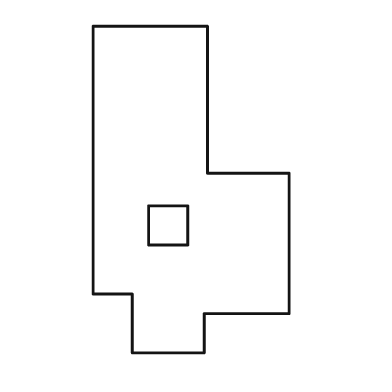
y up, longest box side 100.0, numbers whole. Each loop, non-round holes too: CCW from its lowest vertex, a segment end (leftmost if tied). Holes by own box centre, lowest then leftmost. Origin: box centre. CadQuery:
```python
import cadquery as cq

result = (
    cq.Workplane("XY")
    .moveTo(-18.0, -50.0)
    .lineTo(4.0, -50.0)
    .lineTo(4.0, -38.0)
    .lineTo(30.0, -38.0)
    .lineTo(30.0, 5.0)
    .lineTo(5.0, 5.0)
    .lineTo(5.0, 50.0)
    .lineTo(-30.0, 50.0)
    .lineTo(-30.0, -32.0)
    .lineTo(-18.0, -32.0)
    .close()
    .moveTo(-13.0, -17.0)
    .lineTo(-1.0, -17.0)
    .lineTo(-1.0, -5.0)
    .lineTo(-13.0, -5.0)
    .close()
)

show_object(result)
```